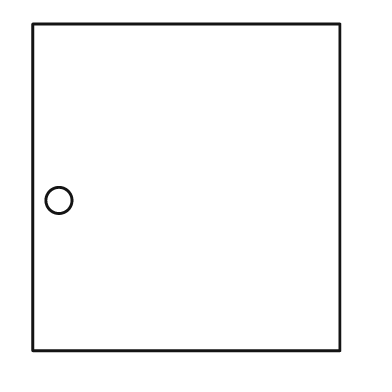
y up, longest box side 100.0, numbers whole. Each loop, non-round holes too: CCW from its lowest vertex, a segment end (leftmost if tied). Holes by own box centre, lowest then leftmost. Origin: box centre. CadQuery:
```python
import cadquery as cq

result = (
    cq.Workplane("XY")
    .moveTo(-47.0, -50.0)
    .lineTo(47.0, -50.0)
    .lineTo(47.0, 50.0)
    .lineTo(-47.0, 50.0)
    .close()
    .moveTo(-39.0, -4.0)
    .circle(4.0)
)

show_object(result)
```